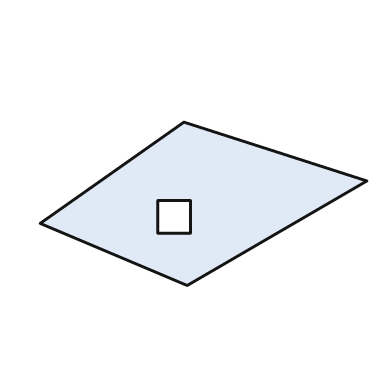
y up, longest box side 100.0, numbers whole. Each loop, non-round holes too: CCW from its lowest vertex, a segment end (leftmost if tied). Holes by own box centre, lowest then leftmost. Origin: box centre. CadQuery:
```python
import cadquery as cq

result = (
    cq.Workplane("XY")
    .moveTo(-5.0, -25.0)
    .lineTo(50.0, 7.0)
    .lineTo(-6.0, 25.0)
    .lineTo(-50.0, -6.0)
    .close()
    .moveTo(-14.0, -9.0)
    .lineTo(-4.0, -9.0)
    .lineTo(-4.0, 1.0)
    .lineTo(-14.0, 1.0)
    .close()
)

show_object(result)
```